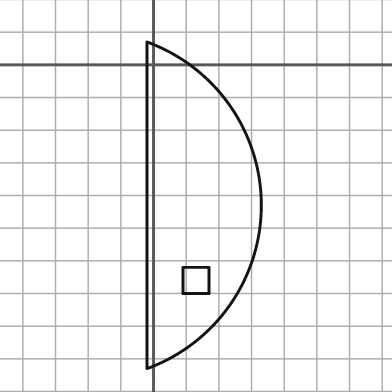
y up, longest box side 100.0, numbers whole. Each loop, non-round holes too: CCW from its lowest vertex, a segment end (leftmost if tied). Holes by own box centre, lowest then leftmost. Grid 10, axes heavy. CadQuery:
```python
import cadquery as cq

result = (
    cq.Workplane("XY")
    .moveTo(-2.0, -93.0)
    .threePointArc((33.0, -43.0), (-2.0, 7.0))
    .close()
    .moveTo(9.0, -70.0)
    .lineTo(17.0, -70.0)
    .lineTo(17.0, -62.0)
    .lineTo(9.0, -62.0)
    .close()
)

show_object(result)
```